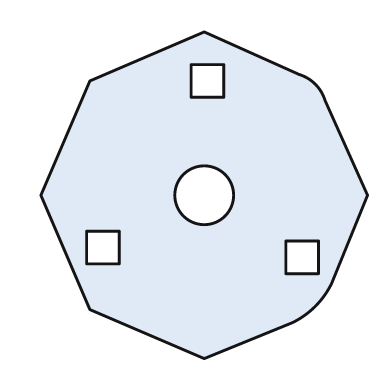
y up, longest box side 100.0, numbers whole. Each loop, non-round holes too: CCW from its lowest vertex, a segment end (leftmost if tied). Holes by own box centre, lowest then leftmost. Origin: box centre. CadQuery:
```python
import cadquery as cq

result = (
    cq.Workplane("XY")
    .moveTo(0.0, -50.0)
    .lineTo(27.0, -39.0)
    .threePointArc((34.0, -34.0), (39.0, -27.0))
    .lineTo(50.0, 0.0)
    .lineTo(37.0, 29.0)
    .threePointArc((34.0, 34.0), (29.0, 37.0))
    .lineTo(0.0, 50.0)
    .lineTo(-35.0, 35.0)
    .lineTo(-50.0, 0.0)
    .lineTo(-35.0, -35.0)
    .close()
    .moveTo(25.0, -24.0)
    .lineTo(35.0, -24.0)
    .lineTo(35.0, -14.0)
    .lineTo(25.0, -14.0)
    .close()
    .moveTo(-36.0, -21.0)
    .lineTo(-26.0, -21.0)
    .lineTo(-26.0, -11.0)
    .lineTo(-36.0, -11.0)
    .close()
    .moveTo(0.0, 0.0)
    .circle(9.0)
    .moveTo(-4.0, 30.0)
    .lineTo(6.0, 30.0)
    .lineTo(6.0, 40.0)
    .lineTo(-4.0, 40.0)
    .close()
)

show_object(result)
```